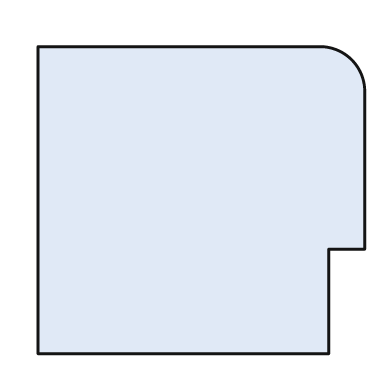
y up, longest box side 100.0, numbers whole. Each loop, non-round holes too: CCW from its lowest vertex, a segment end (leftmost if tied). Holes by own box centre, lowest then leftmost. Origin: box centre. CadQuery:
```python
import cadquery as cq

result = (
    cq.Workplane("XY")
    .moveTo(-50.0, -47.0)
    .lineTo(39.0, -47.0)
    .lineTo(39.0, -15.0)
    .lineTo(50.0, -15.0)
    .lineTo(50.0, 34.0)
    .threePointArc((46.0, 43.0), (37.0, 47.0))
    .lineTo(-50.0, 47.0)
    .close()
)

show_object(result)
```